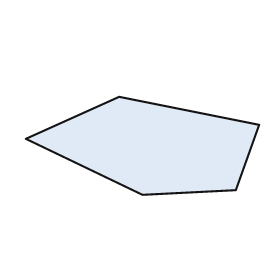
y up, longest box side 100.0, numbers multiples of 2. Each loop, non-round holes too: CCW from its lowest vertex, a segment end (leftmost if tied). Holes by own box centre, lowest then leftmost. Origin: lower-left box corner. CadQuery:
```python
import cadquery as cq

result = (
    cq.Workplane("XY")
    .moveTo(50.0, 0.0)
    .lineTo(90.0, 2.0)
    .lineTo(100.0, 30.0)
    .lineTo(40.0, 42.0)
    .lineTo(0.0, 24.0)
    .close()
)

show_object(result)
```